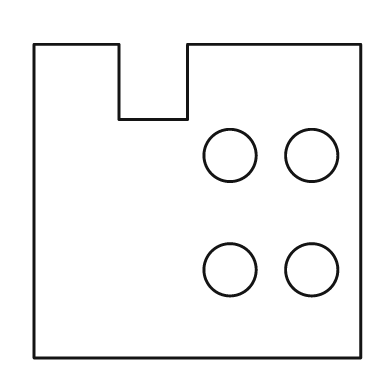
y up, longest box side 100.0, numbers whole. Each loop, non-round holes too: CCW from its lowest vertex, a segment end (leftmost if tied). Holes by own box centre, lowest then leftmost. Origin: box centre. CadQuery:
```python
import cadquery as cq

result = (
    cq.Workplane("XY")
    .moveTo(-50.0, -48.0)
    .lineTo(50.0, -48.0)
    .lineTo(50.0, 48.0)
    .lineTo(-3.0, 48.0)
    .lineTo(-3.0, 25.0)
    .lineTo(-24.0, 25.0)
    .lineTo(-24.0, 48.0)
    .lineTo(-50.0, 48.0)
    .close()
    .moveTo(10.0, -21.0)
    .circle(8.0)
    .moveTo(35.0, -21.0)
    .circle(8.0)
    .moveTo(10.0, 14.0)
    .circle(8.0)
    .moveTo(35.0, 14.0)
    .circle(8.0)
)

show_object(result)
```